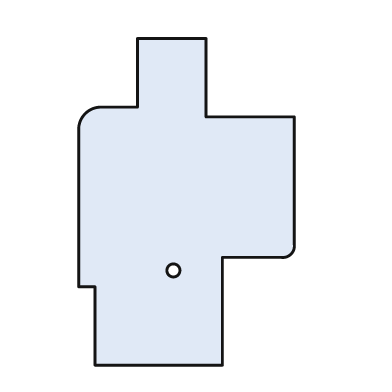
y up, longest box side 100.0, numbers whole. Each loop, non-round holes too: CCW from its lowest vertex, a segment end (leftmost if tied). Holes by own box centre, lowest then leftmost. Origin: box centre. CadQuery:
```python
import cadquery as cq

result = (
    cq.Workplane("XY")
    .moveTo(-28.0, -50.0)
    .lineTo(11.0, -50.0)
    .lineTo(11.0, -17.0)
    .lineTo(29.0, -17.0)
    .threePointArc((32.0, -16.0), (33.0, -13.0))
    .lineTo(33.0, 26.0)
    .lineTo(6.0, 26.0)
    .lineTo(6.0, 50.0)
    .lineTo(-15.0, 50.0)
    .lineTo(-15.0, 29.0)
    .lineTo(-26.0, 29.0)
    .threePointArc((-31.0, 27.0), (-33.0, 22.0))
    .lineTo(-33.0, -26.0)
    .lineTo(-28.0, -26.0)
    .close()
    .moveTo(-4.0, -21.0)
    .circle(2.0)
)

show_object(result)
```